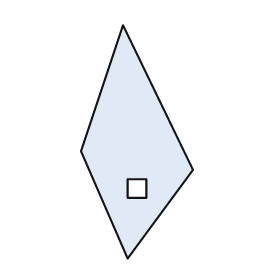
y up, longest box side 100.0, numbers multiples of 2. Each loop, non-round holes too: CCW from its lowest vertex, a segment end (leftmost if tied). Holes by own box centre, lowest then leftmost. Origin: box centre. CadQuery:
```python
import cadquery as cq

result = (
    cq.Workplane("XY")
    .moveTo(-4.0, -50.0)
    .lineTo(24.0, -12.0)
    .lineTo(-6.0, 50.0)
    .lineTo(-24.0, -4.0)
    .close()
    .moveTo(-4.0, -24.0)
    .lineTo(4.0, -24.0)
    .lineTo(4.0, -16.0)
    .lineTo(-4.0, -16.0)
    .close()
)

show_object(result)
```